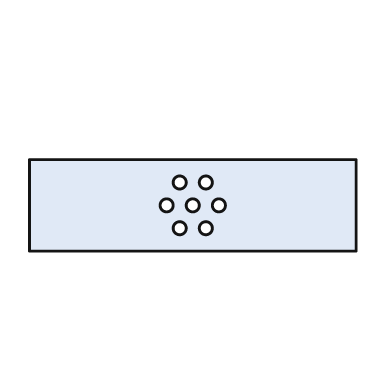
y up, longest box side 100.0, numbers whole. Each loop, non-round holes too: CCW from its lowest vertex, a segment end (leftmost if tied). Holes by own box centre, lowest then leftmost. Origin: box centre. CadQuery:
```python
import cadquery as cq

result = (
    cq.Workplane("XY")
    .moveTo(-50.0, -14.0)
    .lineTo(50.0, -14.0)
    .lineTo(50.0, 14.0)
    .lineTo(-50.0, 14.0)
    .close()
    .moveTo(-4.0, -7.0)
    .circle(2.0)
    .moveTo(4.0, -7.0)
    .circle(2.0)
    .moveTo(-8.0, 0.0)
    .circle(2.0)
    .moveTo(0.0, 0.0)
    .circle(2.0)
    .moveTo(8.0, 0.0)
    .circle(2.0)
    .moveTo(-4.0, 7.0)
    .circle(2.0)
    .moveTo(4.0, 7.0)
    .circle(2.0)
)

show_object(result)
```